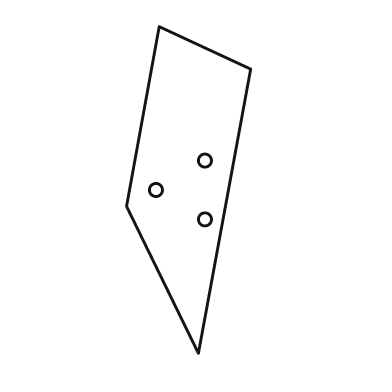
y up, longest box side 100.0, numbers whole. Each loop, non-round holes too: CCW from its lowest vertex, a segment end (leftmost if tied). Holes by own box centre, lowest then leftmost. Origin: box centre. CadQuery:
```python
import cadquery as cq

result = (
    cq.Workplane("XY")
    .moveTo(3.0, -50.0)
    .lineTo(19.0, 37.0)
    .lineTo(-9.0, 50.0)
    .lineTo(-19.0, -5.0)
    .close()
    .moveTo(5.0, -9.0)
    .circle(2.0)
    .moveTo(-10.0, 0.0)
    .circle(2.0)
    .moveTo(5.0, 9.0)
    .circle(2.0)
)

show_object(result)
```